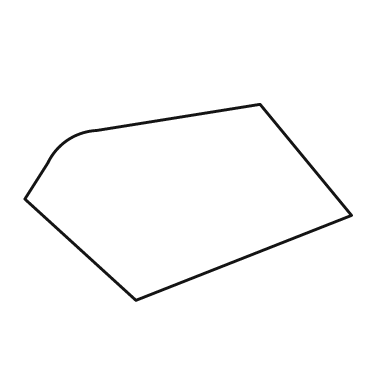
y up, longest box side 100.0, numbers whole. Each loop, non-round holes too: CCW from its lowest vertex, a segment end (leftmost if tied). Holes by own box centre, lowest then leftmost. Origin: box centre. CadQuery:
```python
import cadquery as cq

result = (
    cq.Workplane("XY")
    .moveTo(-16.0, -30.0)
    .lineTo(50.0, -4.0)
    .lineTo(22.0, 30.0)
    .lineTo(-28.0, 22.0)
    .threePointArc((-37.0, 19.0), (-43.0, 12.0))
    .lineTo(-50.0, 1.0)
    .close()
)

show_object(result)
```